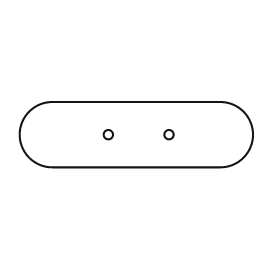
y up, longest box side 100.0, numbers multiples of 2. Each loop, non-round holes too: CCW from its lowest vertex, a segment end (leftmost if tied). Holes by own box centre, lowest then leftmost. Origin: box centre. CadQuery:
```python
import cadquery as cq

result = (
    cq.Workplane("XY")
    .moveTo(-36.0, -14.0)
    .lineTo(36.0, -14.0)
    .threePointArc((50.0, 0.0), (36.0, 14.0))
    .lineTo(-36.0, 14.0)
    .threePointArc((-50.0, 0.0), (-36.0, -14.0))
    .close()
    .moveTo(-12.0, 0.0)
    .circle(2.0)
    .moveTo(14.0, 0.0)
    .circle(2.0)
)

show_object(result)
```